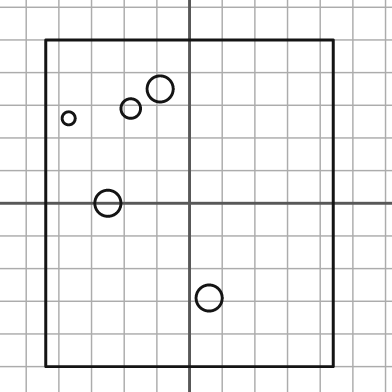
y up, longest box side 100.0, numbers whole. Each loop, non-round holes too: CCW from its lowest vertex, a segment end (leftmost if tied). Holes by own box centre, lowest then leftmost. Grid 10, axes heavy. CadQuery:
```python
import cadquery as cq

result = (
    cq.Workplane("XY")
    .moveTo(-44.0, -50.0)
    .lineTo(44.0, -50.0)
    .lineTo(44.0, 50.0)
    .lineTo(-44.0, 50.0)
    .close()
    .moveTo(6.0, -29.0)
    .circle(4.0)
    .moveTo(-25.0, 0.0)
    .circle(4.0)
    .moveTo(-37.0, 26.0)
    .circle(2.0)
    .moveTo(-18.0, 29.0)
    .circle(3.0)
    .moveTo(-9.0, 35.0)
    .circle(4.0)
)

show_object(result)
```